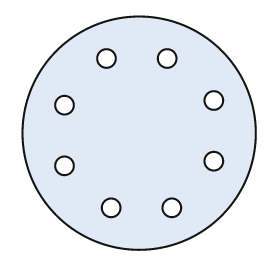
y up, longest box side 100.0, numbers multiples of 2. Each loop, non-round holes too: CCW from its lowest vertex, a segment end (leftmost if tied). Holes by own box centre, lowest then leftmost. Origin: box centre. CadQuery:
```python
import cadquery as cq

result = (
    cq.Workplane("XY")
    .moveTo(0.0, 0.0)
    .circle(50.0)
    .moveTo(-12.0, -32.0)
    .circle(4.0)
    .moveTo(14.0, -32.0)
    .circle(4.0)
    .moveTo(-32.0, -14.0)
    .circle(4.0)
    .moveTo(32.0, -12.0)
    .circle(4.0)
    .moveTo(-32.0, 12.0)
    .circle(4.0)
    .moveTo(32.0, 14.0)
    .circle(4.0)
    .moveTo(-14.0, 32.0)
    .circle(4.0)
    .moveTo(12.0, 32.0)
    .circle(4.0)
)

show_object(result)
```